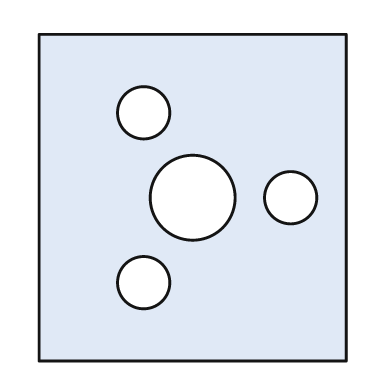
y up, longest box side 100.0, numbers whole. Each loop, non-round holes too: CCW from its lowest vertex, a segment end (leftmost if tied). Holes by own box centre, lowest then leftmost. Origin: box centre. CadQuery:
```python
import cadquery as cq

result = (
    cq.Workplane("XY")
    .moveTo(-47.0, -50.0)
    .lineTo(47.0, -50.0)
    .lineTo(47.0, 50.0)
    .lineTo(-47.0, 50.0)
    .close()
    .moveTo(-15.0, -26.0)
    .circle(8.0)
    .moveTo(0.0, 0.0)
    .circle(13.0)
    .moveTo(30.0, 0.0)
    .circle(8.0)
    .moveTo(-15.0, 26.0)
    .circle(8.0)
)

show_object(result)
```